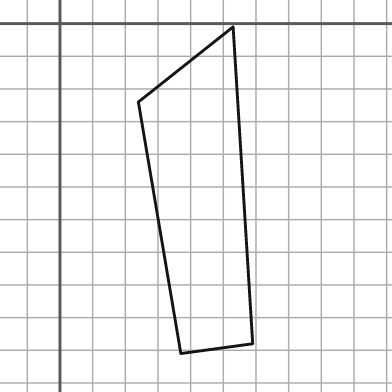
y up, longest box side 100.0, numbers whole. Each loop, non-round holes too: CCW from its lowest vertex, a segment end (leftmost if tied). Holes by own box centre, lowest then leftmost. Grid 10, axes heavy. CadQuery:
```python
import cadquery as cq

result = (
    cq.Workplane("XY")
    .moveTo(37.0, -101.0)
    .lineTo(59.0, -98.0)
    .lineTo(53.0, -1.0)
    .lineTo(24.0, -24.0)
    .close()
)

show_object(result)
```